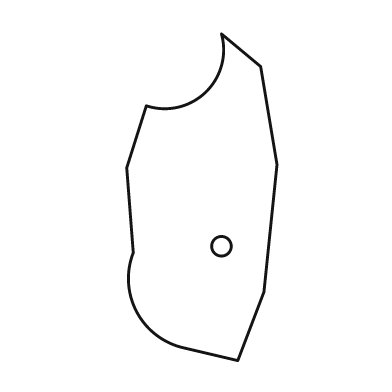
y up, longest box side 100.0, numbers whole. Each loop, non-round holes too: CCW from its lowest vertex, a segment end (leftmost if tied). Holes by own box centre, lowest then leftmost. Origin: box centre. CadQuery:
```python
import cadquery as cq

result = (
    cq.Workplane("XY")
    .moveTo(11.0, -50.0)
    .lineTo(19.0, -29.0)
    .lineTo(23.0, 10.0)
    .lineTo(18.0, 40.0)
    .lineTo(6.0, 50.0)
    .threePointArc((1.0, 32.0), (-17.0, 28.0))
    .lineTo(-23.0, 9.0)
    .lineTo(-21.0, -17.0)
    .threePointArc((-20.0, -35.0), (-6.0, -46.0))
    .close()
    .moveTo(6.0, -15.0)
    .circle(3.0)
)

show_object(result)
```